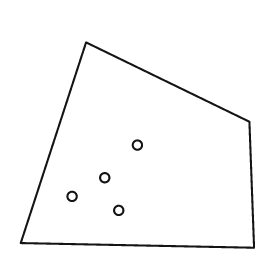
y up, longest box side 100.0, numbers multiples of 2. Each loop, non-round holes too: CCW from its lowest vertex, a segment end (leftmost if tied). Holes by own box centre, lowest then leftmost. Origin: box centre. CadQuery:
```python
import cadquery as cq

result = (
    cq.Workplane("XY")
    .moveTo(50.0, -44.0)
    .lineTo(48.0, 10.0)
    .lineTo(-22.0, 44.0)
    .lineTo(-50.0, -42.0)
    .close()
    .moveTo(-8.0, -28.0)
    .circle(2.0)
    .moveTo(-28.0, -22.0)
    .circle(2.0)
    .moveTo(-14.0, -14.0)
    .circle(2.0)
    .moveTo(0.0, 0.0)
    .circle(2.0)
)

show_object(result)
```